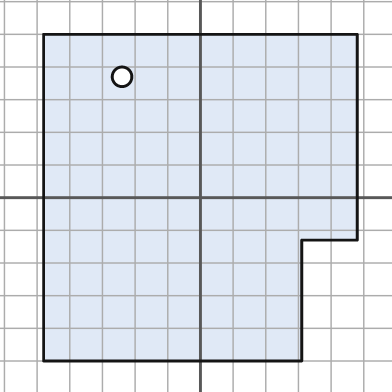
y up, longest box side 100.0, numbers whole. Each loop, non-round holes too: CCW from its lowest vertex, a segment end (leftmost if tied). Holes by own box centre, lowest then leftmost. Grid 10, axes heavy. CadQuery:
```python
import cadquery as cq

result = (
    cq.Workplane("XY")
    .moveTo(-48.0, -50.0)
    .lineTo(31.0, -50.0)
    .lineTo(31.0, -13.0)
    .lineTo(48.0, -13.0)
    .lineTo(48.0, 50.0)
    .lineTo(-48.0, 50.0)
    .close()
    .moveTo(-24.0, 37.0)
    .circle(3.0)
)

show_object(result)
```